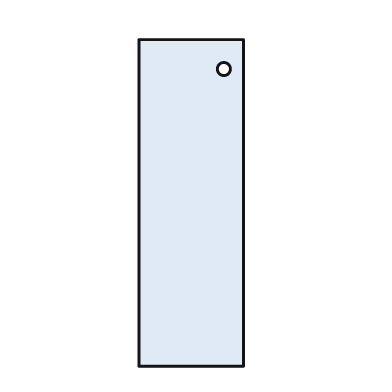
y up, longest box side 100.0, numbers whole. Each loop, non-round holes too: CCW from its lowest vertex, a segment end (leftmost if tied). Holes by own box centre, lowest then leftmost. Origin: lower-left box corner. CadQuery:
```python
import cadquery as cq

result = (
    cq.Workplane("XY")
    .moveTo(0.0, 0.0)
    .lineTo(32.0, 0.0)
    .lineTo(32.0, 100.0)
    .lineTo(0.0, 100.0)
    .close()
    .moveTo(26.0, 91.0)
    .circle(2.0)
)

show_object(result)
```